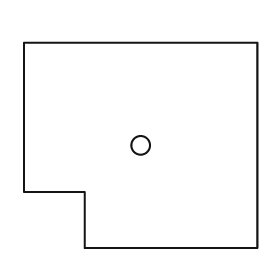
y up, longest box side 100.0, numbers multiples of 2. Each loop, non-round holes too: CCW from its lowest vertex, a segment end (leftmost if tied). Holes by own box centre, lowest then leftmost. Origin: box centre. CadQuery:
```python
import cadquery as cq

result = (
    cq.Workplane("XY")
    .moveTo(-24.0, -44.0)
    .lineTo(50.0, -44.0)
    .lineTo(50.0, 44.0)
    .lineTo(-50.0, 44.0)
    .lineTo(-50.0, -20.0)
    .lineTo(-24.0, -20.0)
    .close()
    .moveTo(0.0, 0.0)
    .circle(4.0)
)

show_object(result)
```